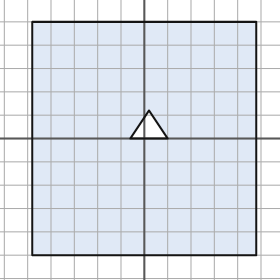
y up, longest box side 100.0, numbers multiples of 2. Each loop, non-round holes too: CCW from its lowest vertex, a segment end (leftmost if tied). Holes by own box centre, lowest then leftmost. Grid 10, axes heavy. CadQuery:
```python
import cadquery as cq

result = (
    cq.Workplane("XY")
    .moveTo(-48.0, -50.0)
    .lineTo(48.0, -50.0)
    .lineTo(48.0, 50.0)
    .lineTo(-48.0, 50.0)
    .close()
    .moveTo(-6.0, 0.0)
    .lineTo(10.0, 0.0)
    .lineTo(2.0, 12.0)
    .close()
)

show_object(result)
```